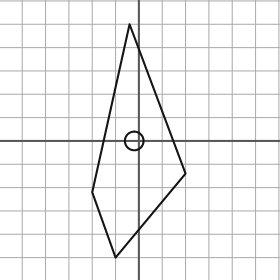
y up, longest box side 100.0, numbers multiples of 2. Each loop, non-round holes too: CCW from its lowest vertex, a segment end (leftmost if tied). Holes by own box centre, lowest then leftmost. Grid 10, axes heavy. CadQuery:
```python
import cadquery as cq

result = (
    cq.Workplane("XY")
    .moveTo(-10.0, -50.0)
    .lineTo(20.0, -14.0)
    .lineTo(-4.0, 50.0)
    .lineTo(-20.0, -22.0)
    .close()
    .moveTo(-2.0, 0.0)
    .circle(4.0)
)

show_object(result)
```